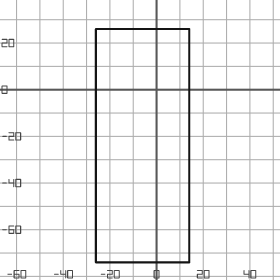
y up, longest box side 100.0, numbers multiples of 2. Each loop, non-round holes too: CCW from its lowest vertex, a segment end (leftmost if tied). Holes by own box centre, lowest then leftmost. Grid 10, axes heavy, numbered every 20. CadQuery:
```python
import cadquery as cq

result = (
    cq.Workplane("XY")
    .moveTo(-26.0, -74.0)
    .lineTo(14.0, -74.0)
    .lineTo(14.0, 26.0)
    .lineTo(-26.0, 26.0)
    .close()
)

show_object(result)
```